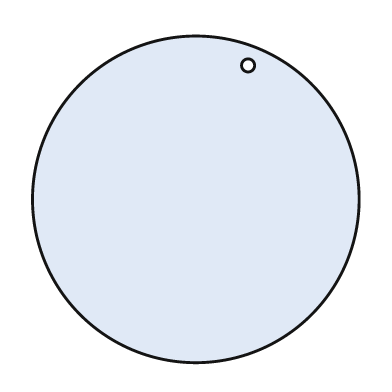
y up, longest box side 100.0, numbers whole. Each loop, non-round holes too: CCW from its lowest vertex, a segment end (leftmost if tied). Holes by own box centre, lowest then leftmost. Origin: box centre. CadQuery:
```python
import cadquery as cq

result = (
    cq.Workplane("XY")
    .moveTo(0.0, 0.0)
    .circle(50.0)
    .moveTo(16.0, 41.0)
    .circle(2.0)
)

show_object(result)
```